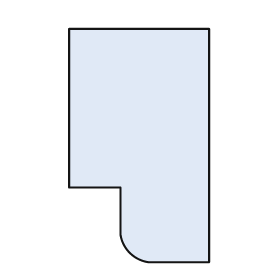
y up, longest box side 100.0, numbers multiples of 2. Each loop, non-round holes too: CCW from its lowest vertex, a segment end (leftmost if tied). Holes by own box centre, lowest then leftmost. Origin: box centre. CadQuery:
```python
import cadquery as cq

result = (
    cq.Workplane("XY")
    .moveTo(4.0, -50.0)
    .lineTo(30.0, -50.0)
    .lineTo(30.0, 50.0)
    .lineTo(-30.0, 50.0)
    .lineTo(-30.0, -18.0)
    .lineTo(-8.0, -18.0)
    .lineTo(-8.0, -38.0)
    .threePointArc((-4.0, -46.0), (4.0, -50.0))
    .close()
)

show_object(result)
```